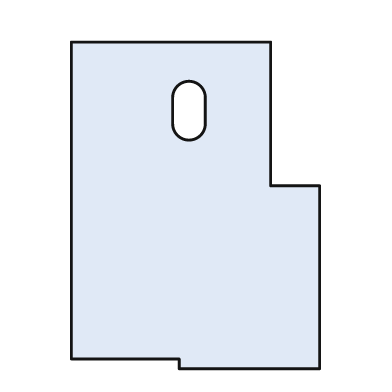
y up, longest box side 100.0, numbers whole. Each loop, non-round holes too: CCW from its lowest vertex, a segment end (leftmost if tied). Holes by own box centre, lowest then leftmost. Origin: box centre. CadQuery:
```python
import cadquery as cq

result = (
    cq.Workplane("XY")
    .moveTo(-5.0, -50.0)
    .lineTo(38.0, -50.0)
    .lineTo(38.0, 6.0)
    .lineTo(23.0, 6.0)
    .lineTo(23.0, 50.0)
    .lineTo(-38.0, 50.0)
    .lineTo(-38.0, -47.0)
    .lineTo(-5.0, -47.0)
    .close()
    .moveTo(-7.0, 25.0)
    .threePointArc((-2.0, 20.0), (3.0, 25.0))
    .lineTo(3.0, 33.0)
    .threePointArc((-2.0, 38.0), (-7.0, 33.0))
    .close()
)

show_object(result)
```